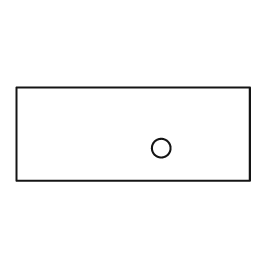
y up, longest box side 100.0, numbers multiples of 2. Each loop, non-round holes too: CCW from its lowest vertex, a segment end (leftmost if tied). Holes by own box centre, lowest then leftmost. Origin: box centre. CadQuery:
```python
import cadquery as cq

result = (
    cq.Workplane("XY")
    .moveTo(-50.0, -20.0)
    .lineTo(50.0, -20.0)
    .lineTo(50.0, 20.0)
    .lineTo(-50.0, 20.0)
    .close()
    .moveTo(12.0, -6.0)
    .circle(4.0)
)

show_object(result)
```